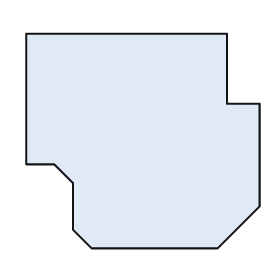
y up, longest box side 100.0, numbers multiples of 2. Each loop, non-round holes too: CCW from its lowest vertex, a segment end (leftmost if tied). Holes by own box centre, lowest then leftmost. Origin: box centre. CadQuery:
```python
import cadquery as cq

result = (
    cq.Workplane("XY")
    .moveTo(-22.0, -46.0)
    .lineTo(32.0, -46.0)
    .lineTo(50.0, -28.0)
    .lineTo(50.0, 16.0)
    .lineTo(36.0, 16.0)
    .lineTo(36.0, 46.0)
    .lineTo(-50.0, 46.0)
    .lineTo(-50.0, -10.0)
    .lineTo(-38.0, -10.0)
    .lineTo(-30.0, -18.0)
    .lineTo(-30.0, -38.0)
    .close()
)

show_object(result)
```